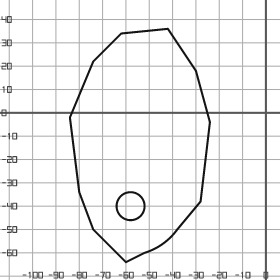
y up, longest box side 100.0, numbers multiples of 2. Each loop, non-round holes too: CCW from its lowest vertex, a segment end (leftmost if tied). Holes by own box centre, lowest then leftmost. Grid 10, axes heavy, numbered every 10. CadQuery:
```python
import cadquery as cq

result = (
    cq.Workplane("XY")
    .moveTo(-60.0, -64.0)
    .lineTo(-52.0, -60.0)
    .threePointArc((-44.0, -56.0), (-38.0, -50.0))
    .lineTo(-28.0, -38.0)
    .lineTo(-24.0, -4.0)
    .lineTo(-30.0, 18.0)
    .lineTo(-42.0, 36.0)
    .lineTo(-62.0, 34.0)
    .lineTo(-74.0, 22.0)
    .lineTo(-84.0, -2.0)
    .lineTo(-80.0, -34.0)
    .lineTo(-74.0, -50.0)
    .close()
    .moveTo(-58.0, -40.0)
    .circle(6.0)
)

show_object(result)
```